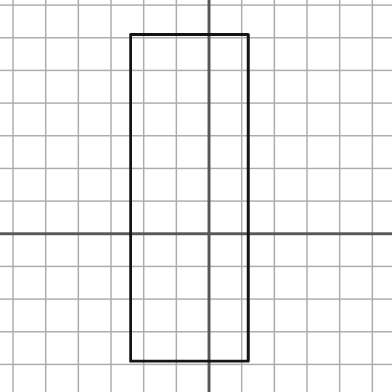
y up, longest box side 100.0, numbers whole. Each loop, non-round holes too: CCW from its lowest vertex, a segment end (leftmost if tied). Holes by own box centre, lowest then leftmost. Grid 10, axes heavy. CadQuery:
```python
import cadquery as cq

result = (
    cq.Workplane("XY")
    .moveTo(-24.0, -39.0)
    .lineTo(12.0, -39.0)
    .lineTo(12.0, 61.0)
    .lineTo(-24.0, 61.0)
    .close()
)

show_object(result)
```